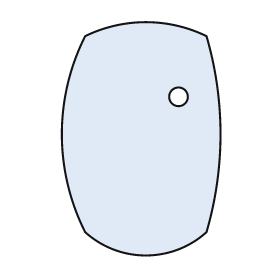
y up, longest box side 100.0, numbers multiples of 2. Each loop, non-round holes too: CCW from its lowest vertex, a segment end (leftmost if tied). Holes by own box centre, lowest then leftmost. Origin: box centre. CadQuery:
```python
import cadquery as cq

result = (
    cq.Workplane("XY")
    .moveTo(-24.0, -40.0)
    .threePointArc((2.0, -50.0), (28.0, -40.0))
    .threePointArc((34.0, 2.0), (28.0, 44.0))
    .threePointArc((2.0, 50.0), (-24.0, 44.0))
    .threePointArc((-34.0, 2.0), (-24.0, -40.0))
    .close()
    .moveTo(16.0, 18.0)
    .circle(4.0)
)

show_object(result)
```